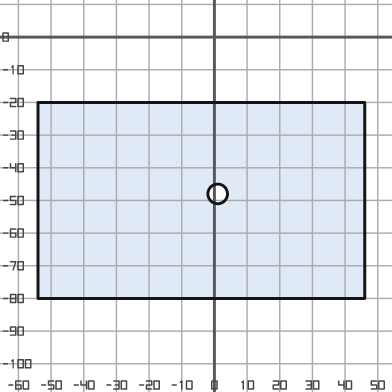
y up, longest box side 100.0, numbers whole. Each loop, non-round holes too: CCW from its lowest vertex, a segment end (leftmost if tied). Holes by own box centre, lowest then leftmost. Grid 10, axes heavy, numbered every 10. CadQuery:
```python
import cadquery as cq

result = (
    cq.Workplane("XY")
    .moveTo(-54.0, -80.0)
    .lineTo(46.0, -80.0)
    .lineTo(46.0, -20.0)
    .lineTo(-54.0, -20.0)
    .close()
    .moveTo(1.0, -48.0)
    .circle(3.0)
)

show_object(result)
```